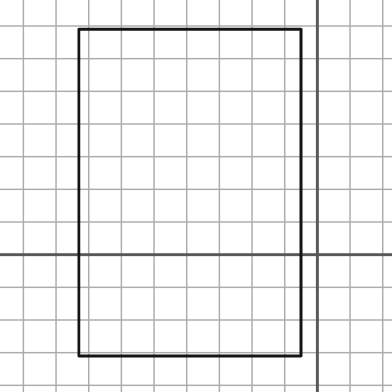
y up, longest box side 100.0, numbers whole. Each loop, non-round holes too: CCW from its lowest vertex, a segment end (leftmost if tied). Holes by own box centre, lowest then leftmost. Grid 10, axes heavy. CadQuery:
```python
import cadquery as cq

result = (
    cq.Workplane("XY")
    .moveTo(-73.0, -31.0)
    .lineTo(-5.0, -31.0)
    .lineTo(-5.0, 69.0)
    .lineTo(-73.0, 69.0)
    .close()
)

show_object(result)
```